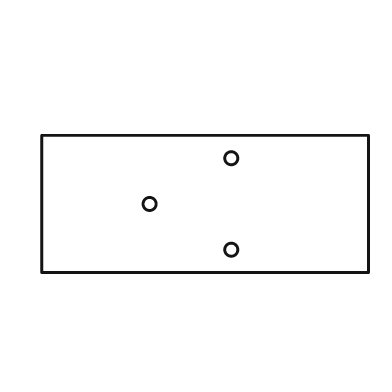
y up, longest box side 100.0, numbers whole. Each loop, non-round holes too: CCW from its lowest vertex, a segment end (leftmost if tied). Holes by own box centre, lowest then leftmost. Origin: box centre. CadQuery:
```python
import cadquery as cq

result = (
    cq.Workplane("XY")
    .moveTo(-50.0, -21.0)
    .lineTo(50.0, -21.0)
    .lineTo(50.0, 21.0)
    .lineTo(-50.0, 21.0)
    .close()
    .moveTo(8.0, -14.0)
    .circle(2.0)
    .moveTo(-17.0, 0.0)
    .circle(2.0)
    .moveTo(8.0, 14.0)
    .circle(2.0)
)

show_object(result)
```